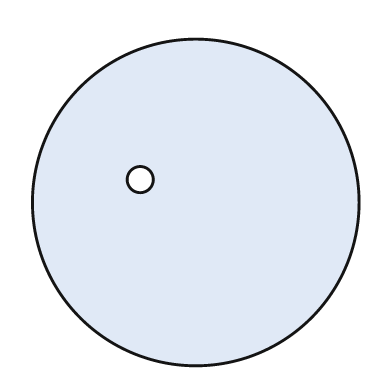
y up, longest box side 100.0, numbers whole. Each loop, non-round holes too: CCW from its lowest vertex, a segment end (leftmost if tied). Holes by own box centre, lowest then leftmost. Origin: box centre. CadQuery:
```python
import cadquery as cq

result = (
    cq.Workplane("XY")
    .moveTo(0.0, 0.0)
    .circle(50.0)
    .moveTo(-17.0, 7.0)
    .circle(4.0)
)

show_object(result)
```